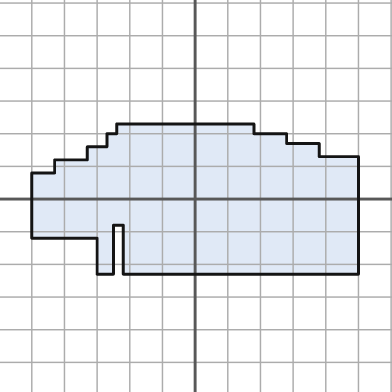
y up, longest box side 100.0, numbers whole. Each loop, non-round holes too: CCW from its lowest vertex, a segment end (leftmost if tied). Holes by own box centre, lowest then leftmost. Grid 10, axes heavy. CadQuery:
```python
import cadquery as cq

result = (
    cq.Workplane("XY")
    .moveTo(-30.0, -23.0)
    .lineTo(-25.0, -23.0)
    .lineTo(-25.0, -8.0)
    .lineTo(-22.0, -8.0)
    .lineTo(-22.0, -23.0)
    .lineTo(50.0, -23.0)
    .lineTo(50.0, 13.0)
    .lineTo(38.0, 13.0)
    .lineTo(38.0, 17.0)
    .lineTo(28.0, 17.0)
    .lineTo(28.0, 20.0)
    .lineTo(18.0, 20.0)
    .lineTo(18.0, 23.0)
    .lineTo(-24.0, 23.0)
    .lineTo(-24.0, 20.0)
    .lineTo(-27.0, 20.0)
    .lineTo(-27.0, 16.0)
    .lineTo(-33.0, 16.0)
    .lineTo(-33.0, 12.0)
    .lineTo(-43.0, 12.0)
    .lineTo(-43.0, 8.0)
    .lineTo(-50.0, 8.0)
    .lineTo(-50.0, -12.0)
    .lineTo(-30.0, -12.0)
    .close()
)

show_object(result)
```